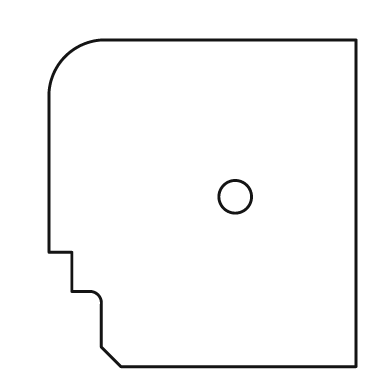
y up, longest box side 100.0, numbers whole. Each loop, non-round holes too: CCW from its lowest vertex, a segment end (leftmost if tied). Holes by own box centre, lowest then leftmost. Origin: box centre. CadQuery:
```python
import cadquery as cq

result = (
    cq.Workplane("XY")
    .moveTo(-25.0, -50.0)
    .lineTo(47.0, -50.0)
    .lineTo(47.0, 50.0)
    .lineTo(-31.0, 50.0)
    .threePointArc((-42.0, 45.0), (-47.0, 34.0))
    .lineTo(-47.0, -15.0)
    .lineTo(-40.0, -15.0)
    .lineTo(-40.0, -27.0)
    .lineTo(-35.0, -27.0)
    .threePointArc((-32.0, -28.0), (-31.0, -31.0))
    .lineTo(-31.0, -44.0)
    .close()
    .moveTo(10.0, 2.0)
    .circle(5.0)
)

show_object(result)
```